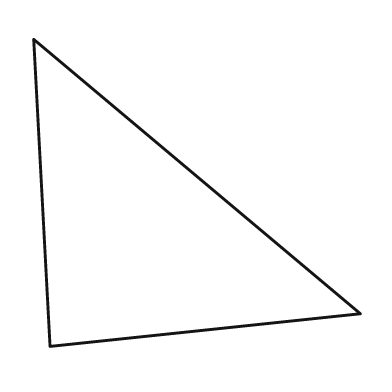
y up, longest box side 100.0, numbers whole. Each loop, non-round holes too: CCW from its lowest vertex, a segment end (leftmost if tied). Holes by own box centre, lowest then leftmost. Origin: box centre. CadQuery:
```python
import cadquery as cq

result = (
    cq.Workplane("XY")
    .moveTo(-45.0, -47.0)
    .lineTo(50.0, -37.0)
    .lineTo(-50.0, 47.0)
    .close()
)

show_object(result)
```